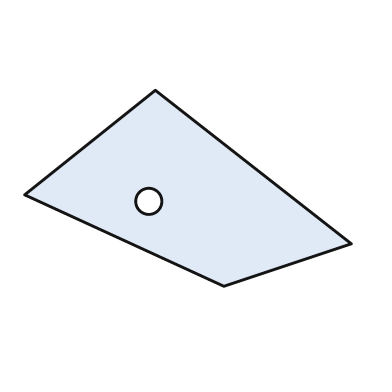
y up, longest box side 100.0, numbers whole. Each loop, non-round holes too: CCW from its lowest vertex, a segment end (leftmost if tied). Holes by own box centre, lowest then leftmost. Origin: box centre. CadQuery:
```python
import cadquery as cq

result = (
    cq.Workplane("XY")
    .moveTo(11.0, -30.0)
    .lineTo(50.0, -17.0)
    .lineTo(-10.0, 30.0)
    .lineTo(-50.0, -2.0)
    .close()
    .moveTo(-12.0, -4.0)
    .circle(4.0)
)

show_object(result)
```